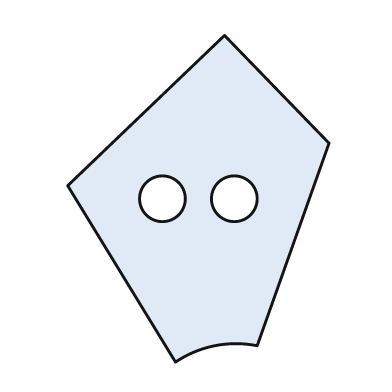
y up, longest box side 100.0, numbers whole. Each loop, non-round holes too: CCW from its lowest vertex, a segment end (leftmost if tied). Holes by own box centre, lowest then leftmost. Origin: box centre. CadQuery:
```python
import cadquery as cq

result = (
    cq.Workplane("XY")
    .moveTo(-7.0, -50.0)
    .threePointArc((5.0, -45.0), (18.0, -45.0))
    .lineTo(40.0, 17.0)
    .lineTo(8.0, 50.0)
    .lineTo(-40.0, 4.0)
    .close()
    .moveTo(-11.0, 0.0)
    .circle(7.0)
    .moveTo(11.0, 0.0)
    .circle(7.0)
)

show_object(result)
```